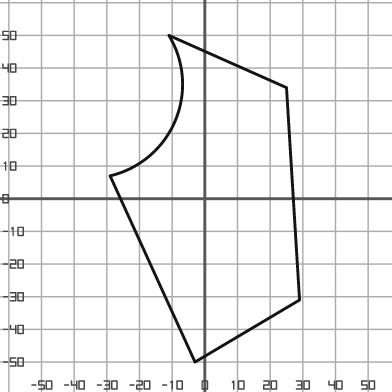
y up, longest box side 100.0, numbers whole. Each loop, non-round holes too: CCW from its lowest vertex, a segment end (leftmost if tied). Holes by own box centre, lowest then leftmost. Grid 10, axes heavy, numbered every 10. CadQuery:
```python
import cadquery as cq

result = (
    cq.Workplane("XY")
    .moveTo(-3.0, -50.0)
    .lineTo(29.0, -31.0)
    .lineTo(25.0, 34.0)
    .lineTo(-11.0, 50.0)
    .threePointArc((-9.0, 24.0), (-29.0, 7.0))
    .close()
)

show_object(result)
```